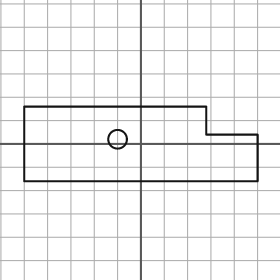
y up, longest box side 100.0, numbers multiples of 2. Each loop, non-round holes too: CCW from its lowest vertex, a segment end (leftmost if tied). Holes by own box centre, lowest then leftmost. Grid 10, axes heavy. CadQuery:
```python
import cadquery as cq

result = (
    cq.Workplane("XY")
    .moveTo(-50.0, -16.0)
    .lineTo(50.0, -16.0)
    .lineTo(50.0, 4.0)
    .lineTo(28.0, 4.0)
    .lineTo(28.0, 16.0)
    .lineTo(-50.0, 16.0)
    .close()
    .moveTo(-10.0, 2.0)
    .circle(4.0)
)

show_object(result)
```